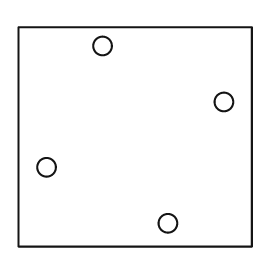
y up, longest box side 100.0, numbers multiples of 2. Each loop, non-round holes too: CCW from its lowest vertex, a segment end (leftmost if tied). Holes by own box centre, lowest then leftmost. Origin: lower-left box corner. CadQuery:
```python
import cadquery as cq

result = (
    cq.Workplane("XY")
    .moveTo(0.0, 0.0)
    .lineTo(100.0, 0.0)
    .lineTo(100.0, 94.0)
    .lineTo(0.0, 94.0)
    .close()
    .moveTo(64.0, 10.0)
    .circle(4.0)
    .moveTo(12.0, 34.0)
    .circle(4.0)
    .moveTo(88.0, 62.0)
    .circle(4.0)
    .moveTo(36.0, 86.0)
    .circle(4.0)
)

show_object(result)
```